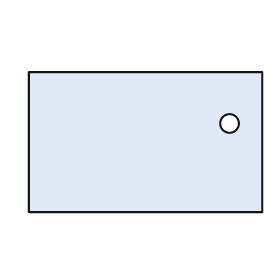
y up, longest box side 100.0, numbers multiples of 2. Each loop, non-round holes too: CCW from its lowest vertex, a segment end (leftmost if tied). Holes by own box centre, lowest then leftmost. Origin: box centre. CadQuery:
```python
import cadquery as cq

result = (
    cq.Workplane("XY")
    .moveTo(-50.0, -30.0)
    .lineTo(50.0, -30.0)
    .lineTo(50.0, 30.0)
    .lineTo(-50.0, 30.0)
    .close()
    .moveTo(36.0, 8.0)
    .circle(4.0)
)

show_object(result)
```